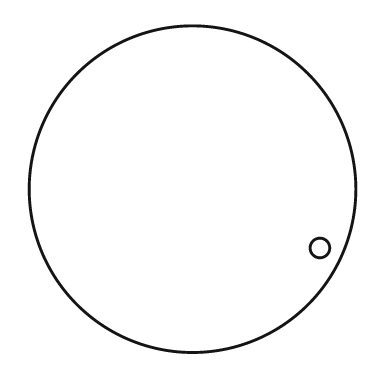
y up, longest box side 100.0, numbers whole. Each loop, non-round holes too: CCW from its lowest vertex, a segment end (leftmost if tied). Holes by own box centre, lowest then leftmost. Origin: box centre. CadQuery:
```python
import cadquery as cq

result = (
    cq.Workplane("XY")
    .moveTo(0.0, 0.0)
    .circle(50.0)
    .moveTo(39.0, -18.0)
    .circle(3.0)
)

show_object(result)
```